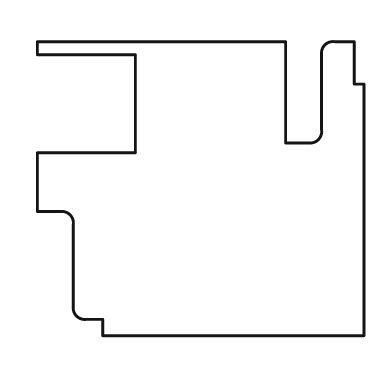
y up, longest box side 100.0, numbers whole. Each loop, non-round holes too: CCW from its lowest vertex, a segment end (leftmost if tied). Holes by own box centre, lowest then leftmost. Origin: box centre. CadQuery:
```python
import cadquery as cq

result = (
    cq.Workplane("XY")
    .moveTo(-30.0, -45.0)
    .lineTo(50.0, -45.0)
    .lineTo(50.0, 32.0)
    .lineTo(47.0, 32.0)
    .lineTo(47.0, 45.0)
    .lineTo(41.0, 45.0)
    .threePointArc((38.0, 44.0), (37.0, 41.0))
    .lineTo(37.0, 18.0)
    .threePointArc((36.0, 15.0), (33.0, 14.0))
    .lineTo(26.0, 14.0)
    .lineTo(26.0, 45.0)
    .lineTo(-50.0, 45.0)
    .lineTo(-50.0, 41.0)
    .lineTo(-20.0, 41.0)
    .lineTo(-20.0, 11.0)
    .lineTo(-50.0, 11.0)
    .lineTo(-50.0, -7.0)
    .lineTo(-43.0, -7.0)
    .threePointArc((-40.0, -8.0), (-39.0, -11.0))
    .lineTo(-39.0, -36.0)
    .threePointArc((-38.0, -39.0), (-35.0, -40.0))
    .lineTo(-30.0, -40.0)
    .close()
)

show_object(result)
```